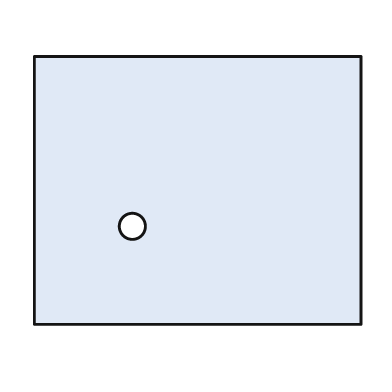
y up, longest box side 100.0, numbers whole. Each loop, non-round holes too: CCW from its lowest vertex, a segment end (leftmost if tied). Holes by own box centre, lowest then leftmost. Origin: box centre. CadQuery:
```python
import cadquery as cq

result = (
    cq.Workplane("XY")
    .moveTo(-50.0, -41.0)
    .lineTo(50.0, -41.0)
    .lineTo(50.0, 41.0)
    .lineTo(-50.0, 41.0)
    .close()
    .moveTo(-20.0, -11.0)
    .circle(4.0)
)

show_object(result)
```